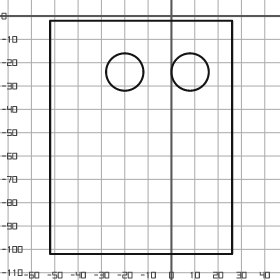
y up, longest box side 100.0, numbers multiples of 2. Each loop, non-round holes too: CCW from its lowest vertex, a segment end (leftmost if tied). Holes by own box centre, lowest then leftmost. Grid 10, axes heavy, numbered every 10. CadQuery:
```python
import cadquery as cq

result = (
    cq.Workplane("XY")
    .moveTo(-52.0, -102.0)
    .lineTo(26.0, -102.0)
    .lineTo(26.0, -2.0)
    .lineTo(-52.0, -2.0)
    .close()
    .moveTo(-20.0, -24.0)
    .circle(8.0)
    .moveTo(8.0, -24.0)
    .circle(8.0)
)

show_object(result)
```